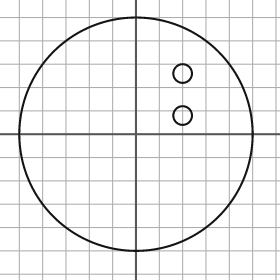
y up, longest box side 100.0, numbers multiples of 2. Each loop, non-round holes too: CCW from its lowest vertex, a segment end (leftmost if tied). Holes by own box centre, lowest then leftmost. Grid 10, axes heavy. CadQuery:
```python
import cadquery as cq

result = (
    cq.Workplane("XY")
    .moveTo(0.0, 0.0)
    .circle(50.0)
    .moveTo(20.0, 8.0)
    .circle(4.0)
    .moveTo(20.0, 26.0)
    .circle(4.0)
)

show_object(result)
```